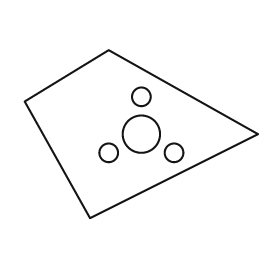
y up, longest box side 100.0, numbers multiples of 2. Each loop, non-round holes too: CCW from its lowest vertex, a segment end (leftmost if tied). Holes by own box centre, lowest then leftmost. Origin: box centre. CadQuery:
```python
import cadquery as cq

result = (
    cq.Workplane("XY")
    .moveTo(-22.0, -36.0)
    .lineTo(50.0, 0.0)
    .lineTo(-14.0, 36.0)
    .lineTo(-50.0, 14.0)
    .close()
    .moveTo(-14.0, -8.0)
    .circle(4.0)
    .moveTo(14.0, -8.0)
    .circle(4.0)
    .moveTo(0.0, 0.0)
    .circle(8.0)
    .moveTo(0.0, 16.0)
    .circle(4.0)
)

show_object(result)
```